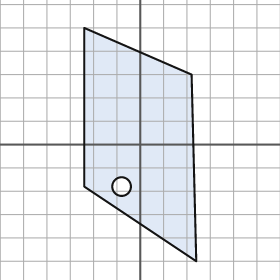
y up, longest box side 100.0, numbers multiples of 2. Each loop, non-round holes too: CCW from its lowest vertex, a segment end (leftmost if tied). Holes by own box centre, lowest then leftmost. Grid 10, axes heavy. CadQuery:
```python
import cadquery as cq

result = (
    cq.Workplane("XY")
    .moveTo(24.0, -50.0)
    .lineTo(22.0, 30.0)
    .lineTo(-24.0, 50.0)
    .lineTo(-24.0, -18.0)
    .close()
    .moveTo(-8.0, -18.0)
    .circle(4.0)
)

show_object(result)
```